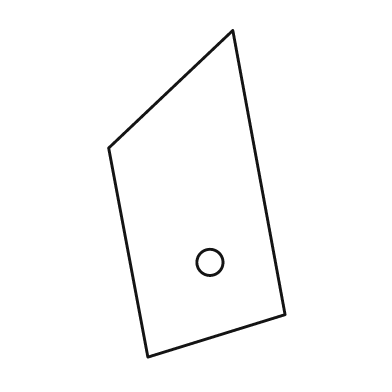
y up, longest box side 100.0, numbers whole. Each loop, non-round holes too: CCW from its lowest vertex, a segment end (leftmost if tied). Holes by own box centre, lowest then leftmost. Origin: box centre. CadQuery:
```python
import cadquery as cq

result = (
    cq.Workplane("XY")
    .moveTo(-15.0, -50.0)
    .lineTo(27.0, -37.0)
    .lineTo(11.0, 50.0)
    .lineTo(-27.0, 14.0)
    .close()
    .moveTo(4.0, -21.0)
    .circle(4.0)
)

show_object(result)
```